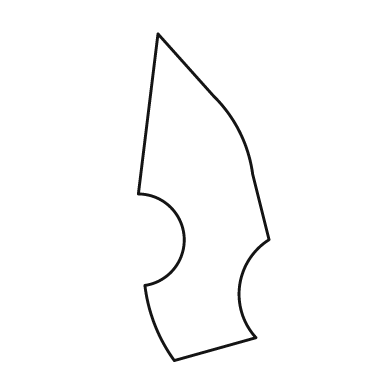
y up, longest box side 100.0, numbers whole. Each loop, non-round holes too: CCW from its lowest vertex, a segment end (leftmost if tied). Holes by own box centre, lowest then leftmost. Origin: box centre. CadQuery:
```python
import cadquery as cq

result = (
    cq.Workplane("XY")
    .moveTo(-9.0, -50.0)
    .lineTo(16.0, -43.0)
    .threePointArc((11.0, -27.0), (20.0, -13.0))
    .lineTo(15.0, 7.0)
    .threePointArc((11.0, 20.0), (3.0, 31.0))
    .lineTo(-14.0, 50.0)
    .lineTo(-20.0, 1.0)
    .threePointArc((-6.0, -12.0), (-18.0, -27.0))
    .threePointArc((-15.0, -39.0), (-9.0, -50.0))
    .close()
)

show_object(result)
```